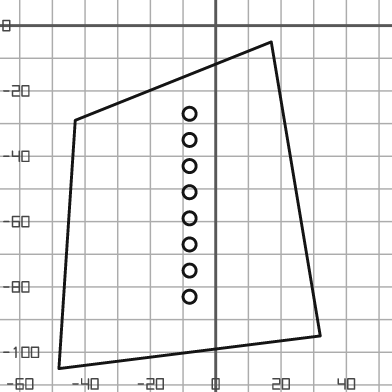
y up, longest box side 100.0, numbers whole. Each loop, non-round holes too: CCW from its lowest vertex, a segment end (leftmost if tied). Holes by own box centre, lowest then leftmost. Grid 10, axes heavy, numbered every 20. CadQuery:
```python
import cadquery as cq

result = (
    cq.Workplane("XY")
    .moveTo(-48.0, -105.0)
    .lineTo(32.0, -95.0)
    .lineTo(17.0, -5.0)
    .lineTo(-43.0, -29.0)
    .close()
    .moveTo(-8.0, -83.0)
    .circle(2.0)
    .moveTo(-8.0, -75.0)
    .circle(2.0)
    .moveTo(-8.0, -67.0)
    .circle(2.0)
    .moveTo(-8.0, -59.0)
    .circle(2.0)
    .moveTo(-8.0, -51.0)
    .circle(2.0)
    .moveTo(-8.0, -43.0)
    .circle(2.0)
    .moveTo(-8.0, -35.0)
    .circle(2.0)
    .moveTo(-8.0, -27.0)
    .circle(2.0)
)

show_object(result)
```